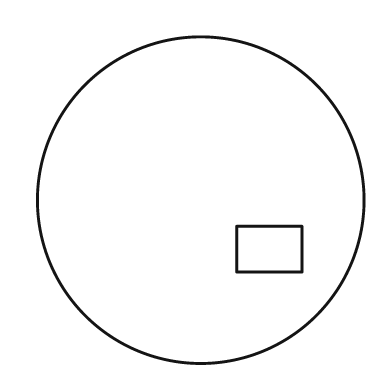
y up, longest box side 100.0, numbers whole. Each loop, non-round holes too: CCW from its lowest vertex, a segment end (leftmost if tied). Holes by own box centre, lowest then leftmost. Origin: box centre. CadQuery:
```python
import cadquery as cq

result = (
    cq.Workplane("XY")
    .moveTo(0.0, 0.0)
    .circle(50.0)
    .moveTo(11.0, -22.0)
    .lineTo(31.0, -22.0)
    .lineTo(31.0, -8.0)
    .lineTo(11.0, -8.0)
    .close()
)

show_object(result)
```